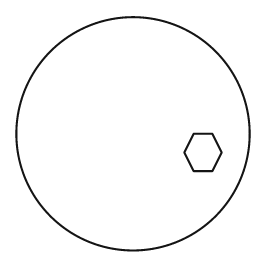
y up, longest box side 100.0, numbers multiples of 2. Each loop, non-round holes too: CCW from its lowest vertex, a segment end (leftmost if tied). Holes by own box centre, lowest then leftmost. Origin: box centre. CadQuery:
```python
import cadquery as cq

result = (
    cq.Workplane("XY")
    .moveTo(0.0, 0.0)
    .circle(50.0)
    .moveTo(26.0, -16.0)
    .lineTo(34.0, -16.0)
    .lineTo(38.0, -8.0)
    .lineTo(34.0, 0.0)
    .lineTo(26.0, 0.0)
    .lineTo(22.0, -8.0)
    .close()
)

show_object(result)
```